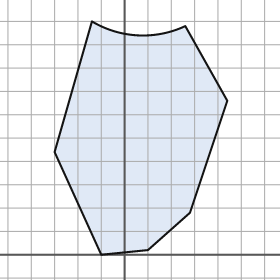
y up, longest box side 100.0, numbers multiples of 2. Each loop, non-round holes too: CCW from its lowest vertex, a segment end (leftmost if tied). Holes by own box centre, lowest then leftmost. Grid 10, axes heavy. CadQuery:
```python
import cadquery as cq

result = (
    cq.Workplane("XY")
    .moveTo(-10.0, 0.0)
    .lineTo(10.0, 2.0)
    .lineTo(28.0, 18.0)
    .lineTo(44.0, 66.0)
    .lineTo(26.0, 98.0)
    .threePointArc((6.0, 94.0), (-14.0, 100.0))
    .lineTo(-30.0, 44.0)
    .close()
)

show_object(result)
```